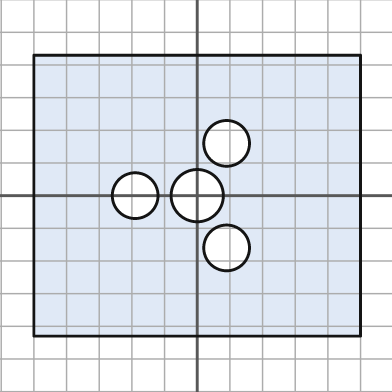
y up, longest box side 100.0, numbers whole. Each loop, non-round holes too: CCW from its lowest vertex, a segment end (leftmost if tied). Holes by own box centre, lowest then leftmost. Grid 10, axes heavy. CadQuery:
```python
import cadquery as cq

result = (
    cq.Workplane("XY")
    .moveTo(-50.0, -43.0)
    .lineTo(50.0, -43.0)
    .lineTo(50.0, 43.0)
    .lineTo(-50.0, 43.0)
    .close()
    .moveTo(9.0, -16.0)
    .circle(7.0)
    .moveTo(-19.0, 0.0)
    .circle(7.0)
    .moveTo(0.0, 0.0)
    .circle(8.0)
    .moveTo(9.0, 16.0)
    .circle(7.0)
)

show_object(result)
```